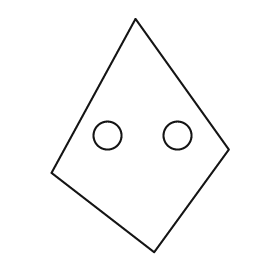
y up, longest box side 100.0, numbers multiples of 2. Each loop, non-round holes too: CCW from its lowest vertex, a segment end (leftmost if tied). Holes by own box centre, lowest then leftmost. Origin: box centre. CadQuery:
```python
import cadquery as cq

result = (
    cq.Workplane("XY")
    .moveTo(6.0, -50.0)
    .lineTo(38.0, -6.0)
    .lineTo(-2.0, 50.0)
    .lineTo(-38.0, -16.0)
    .close()
    .moveTo(-14.0, 0.0)
    .circle(6.0)
    .moveTo(16.0, 0.0)
    .circle(6.0)
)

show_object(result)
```